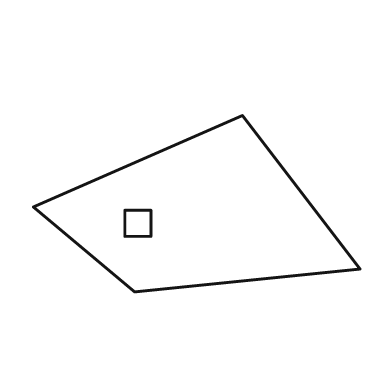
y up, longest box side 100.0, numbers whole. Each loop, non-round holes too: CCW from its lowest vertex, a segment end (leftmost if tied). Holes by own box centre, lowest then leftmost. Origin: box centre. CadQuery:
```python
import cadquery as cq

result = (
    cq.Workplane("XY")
    .moveTo(-19.0, -27.0)
    .lineTo(50.0, -20.0)
    .lineTo(14.0, 27.0)
    .lineTo(-50.0, -1.0)
    .close()
    .moveTo(-22.0, -10.0)
    .lineTo(-14.0, -10.0)
    .lineTo(-14.0, -2.0)
    .lineTo(-22.0, -2.0)
    .close()
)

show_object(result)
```